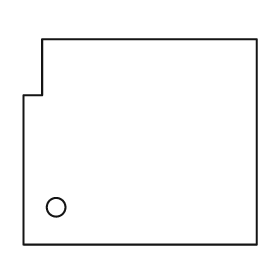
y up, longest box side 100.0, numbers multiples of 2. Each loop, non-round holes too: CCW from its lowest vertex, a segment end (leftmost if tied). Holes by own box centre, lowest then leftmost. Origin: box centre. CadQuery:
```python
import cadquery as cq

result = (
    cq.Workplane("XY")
    .moveTo(-50.0, -44.0)
    .lineTo(50.0, -44.0)
    .lineTo(50.0, 44.0)
    .lineTo(-42.0, 44.0)
    .lineTo(-42.0, 20.0)
    .lineTo(-50.0, 20.0)
    .close()
    .moveTo(-36.0, -28.0)
    .circle(4.0)
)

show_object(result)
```